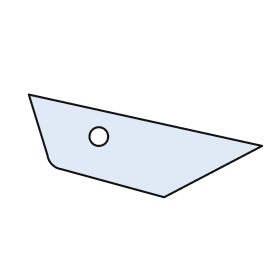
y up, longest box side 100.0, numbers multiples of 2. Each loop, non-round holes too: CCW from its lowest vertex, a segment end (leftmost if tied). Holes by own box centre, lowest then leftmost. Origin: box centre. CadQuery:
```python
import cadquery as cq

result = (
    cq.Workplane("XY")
    .moveTo(8.0, -22.0)
    .lineTo(50.0, 0.0)
    .lineTo(-50.0, 22.0)
    .lineTo(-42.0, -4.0)
    .threePointArc((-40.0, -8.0), (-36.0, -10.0))
    .close()
    .moveTo(-20.0, 4.0)
    .circle(4.0)
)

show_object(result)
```